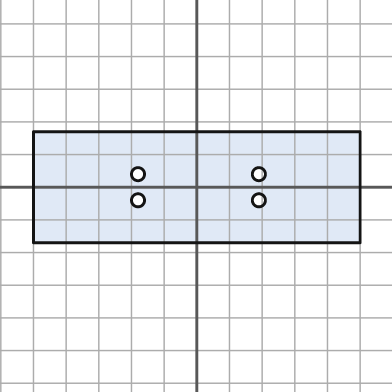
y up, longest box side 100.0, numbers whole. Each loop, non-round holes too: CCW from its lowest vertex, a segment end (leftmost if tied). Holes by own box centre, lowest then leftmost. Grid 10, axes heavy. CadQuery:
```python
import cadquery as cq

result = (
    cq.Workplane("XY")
    .moveTo(-50.0, -17.0)
    .lineTo(50.0, -17.0)
    .lineTo(50.0, 17.0)
    .lineTo(-50.0, 17.0)
    .close()
    .moveTo(-18.0, -4.0)
    .circle(2.0)
    .moveTo(19.0, -4.0)
    .circle(2.0)
    .moveTo(-18.0, 4.0)
    .circle(2.0)
    .moveTo(19.0, 4.0)
    .circle(2.0)
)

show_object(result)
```